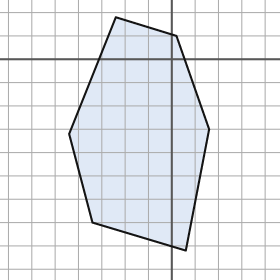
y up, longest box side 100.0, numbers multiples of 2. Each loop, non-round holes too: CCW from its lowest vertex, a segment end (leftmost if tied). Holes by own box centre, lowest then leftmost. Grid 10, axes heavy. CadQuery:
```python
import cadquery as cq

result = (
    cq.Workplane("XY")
    .moveTo(6.0, -82.0)
    .lineTo(16.0, -30.0)
    .lineTo(2.0, 10.0)
    .lineTo(-24.0, 18.0)
    .lineTo(-44.0, -32.0)
    .lineTo(-34.0, -70.0)
    .close()
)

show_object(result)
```